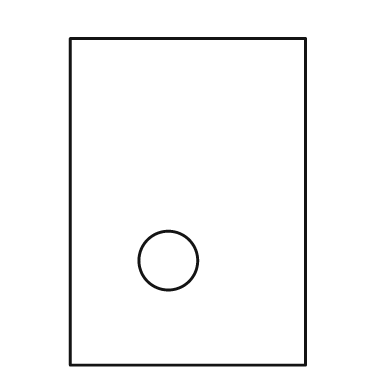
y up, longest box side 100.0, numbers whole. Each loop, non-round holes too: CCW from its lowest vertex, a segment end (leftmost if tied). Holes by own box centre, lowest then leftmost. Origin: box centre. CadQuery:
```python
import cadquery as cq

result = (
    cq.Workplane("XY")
    .moveTo(-36.0, -50.0)
    .lineTo(36.0, -50.0)
    .lineTo(36.0, 50.0)
    .lineTo(-36.0, 50.0)
    .close()
    .moveTo(-6.0, -18.0)
    .circle(9.0)
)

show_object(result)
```